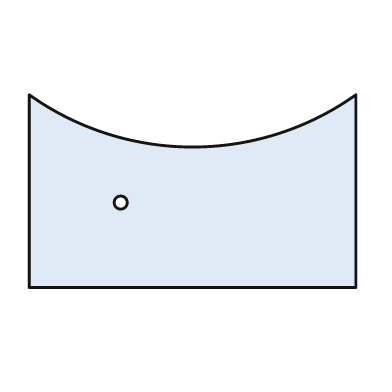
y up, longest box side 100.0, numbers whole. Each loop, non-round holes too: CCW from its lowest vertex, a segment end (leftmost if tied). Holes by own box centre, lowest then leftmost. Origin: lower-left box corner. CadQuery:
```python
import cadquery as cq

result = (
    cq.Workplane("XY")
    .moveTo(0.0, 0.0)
    .lineTo(100.0, 0.0)
    .lineTo(100.0, 59.0)
    .threePointArc((50.0, 43.0), (0.0, 59.0))
    .close()
    .moveTo(28.0, 26.0)
    .circle(2.0)
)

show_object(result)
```